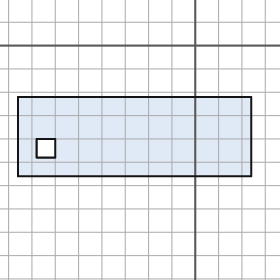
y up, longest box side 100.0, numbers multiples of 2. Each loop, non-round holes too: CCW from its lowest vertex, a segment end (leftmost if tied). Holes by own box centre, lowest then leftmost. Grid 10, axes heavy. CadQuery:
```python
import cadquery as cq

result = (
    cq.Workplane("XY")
    .moveTo(-76.0, -56.0)
    .lineTo(24.0, -56.0)
    .lineTo(24.0, -22.0)
    .lineTo(-76.0, -22.0)
    .close()
    .moveTo(-68.0, -48.0)
    .lineTo(-60.0, -48.0)
    .lineTo(-60.0, -40.0)
    .lineTo(-68.0, -40.0)
    .close()
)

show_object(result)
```